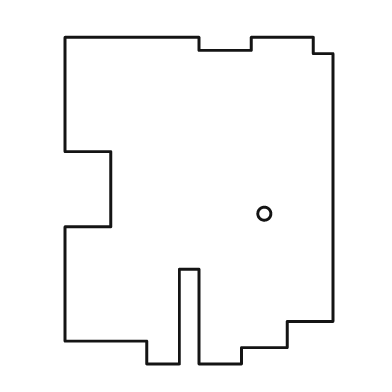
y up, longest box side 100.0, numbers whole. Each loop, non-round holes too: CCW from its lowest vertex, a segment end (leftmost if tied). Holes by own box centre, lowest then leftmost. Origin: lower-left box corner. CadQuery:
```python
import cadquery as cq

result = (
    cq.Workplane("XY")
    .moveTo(25.0, 0.0)
    .lineTo(35.0, 0.0)
    .lineTo(35.0, 29.0)
    .lineTo(41.0, 29.0)
    .lineTo(41.0, 0.0)
    .lineTo(54.0, 0.0)
    .lineTo(54.0, 5.0)
    .lineTo(68.0, 5.0)
    .lineTo(68.0, 13.0)
    .lineTo(82.0, 13.0)
    .lineTo(82.0, 95.0)
    .lineTo(76.0, 95.0)
    .lineTo(76.0, 100.0)
    .lineTo(57.0, 100.0)
    .lineTo(57.0, 96.0)
    .lineTo(41.0, 96.0)
    .lineTo(41.0, 100.0)
    .lineTo(0.0, 100.0)
    .lineTo(0.0, 65.0)
    .lineTo(14.0, 65.0)
    .lineTo(14.0, 42.0)
    .lineTo(0.0, 42.0)
    .lineTo(0.0, 7.0)
    .lineTo(25.0, 7.0)
    .close()
    .moveTo(61.0, 46.0)
    .circle(2.0)
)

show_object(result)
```